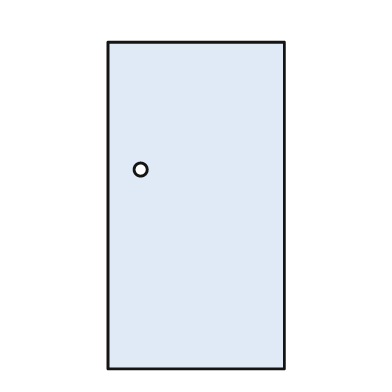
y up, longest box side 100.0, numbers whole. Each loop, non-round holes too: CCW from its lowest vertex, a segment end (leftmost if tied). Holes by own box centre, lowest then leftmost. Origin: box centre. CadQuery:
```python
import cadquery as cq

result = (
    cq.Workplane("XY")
    .moveTo(-27.0, -50.0)
    .lineTo(27.0, -50.0)
    .lineTo(27.0, 50.0)
    .lineTo(-27.0, 50.0)
    .close()
    .moveTo(-17.0, 11.0)
    .circle(2.0)
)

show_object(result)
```